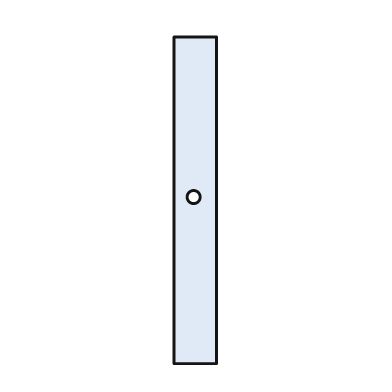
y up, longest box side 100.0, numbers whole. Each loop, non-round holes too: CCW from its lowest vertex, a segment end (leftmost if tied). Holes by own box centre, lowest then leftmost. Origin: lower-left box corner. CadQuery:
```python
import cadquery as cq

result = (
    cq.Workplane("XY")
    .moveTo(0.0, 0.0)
    .lineTo(13.0, 0.0)
    .lineTo(13.0, 100.0)
    .lineTo(0.0, 100.0)
    .close()
    .moveTo(6.0, 51.0)
    .circle(2.0)
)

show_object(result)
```